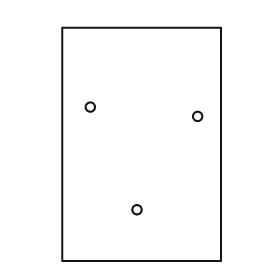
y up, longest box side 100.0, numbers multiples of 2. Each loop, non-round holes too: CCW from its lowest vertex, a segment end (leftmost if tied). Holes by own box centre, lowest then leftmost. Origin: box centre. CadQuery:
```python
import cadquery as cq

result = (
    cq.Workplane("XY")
    .moveTo(-34.0, -50.0)
    .lineTo(34.0, -50.0)
    .lineTo(34.0, 50.0)
    .lineTo(-34.0, 50.0)
    .close()
    .moveTo(-2.0, -28.0)
    .circle(2.0)
    .moveTo(24.0, 12.0)
    .circle(2.0)
    .moveTo(-22.0, 16.0)
    .circle(2.0)
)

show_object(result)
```